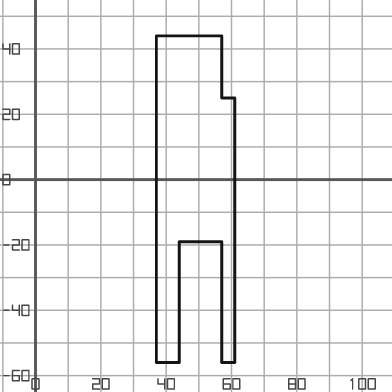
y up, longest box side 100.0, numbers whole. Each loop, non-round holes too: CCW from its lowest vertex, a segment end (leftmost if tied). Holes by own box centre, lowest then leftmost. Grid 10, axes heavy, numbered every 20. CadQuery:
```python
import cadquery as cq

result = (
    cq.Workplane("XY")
    .moveTo(37.0, -56.0)
    .lineTo(44.0, -56.0)
    .lineTo(44.0, -19.0)
    .lineTo(57.0, -19.0)
    .lineTo(57.0, -56.0)
    .lineTo(61.0, -56.0)
    .lineTo(61.0, 25.0)
    .lineTo(57.0, 25.0)
    .lineTo(57.0, 44.0)
    .lineTo(37.0, 44.0)
    .close()
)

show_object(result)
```